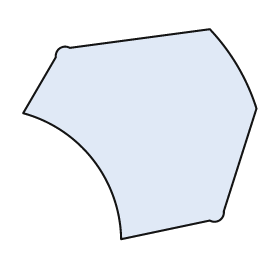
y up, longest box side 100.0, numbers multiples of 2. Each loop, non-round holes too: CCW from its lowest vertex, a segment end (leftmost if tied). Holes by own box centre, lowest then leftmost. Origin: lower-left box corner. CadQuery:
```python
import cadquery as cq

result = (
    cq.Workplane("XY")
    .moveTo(42.0, 0.0)
    .lineTo(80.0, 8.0)
    .threePointArc((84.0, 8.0), (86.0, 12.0))
    .lineTo(100.0, 56.0)
    .threePointArc((92.0, 74.0), (80.0, 90.0))
    .lineTo(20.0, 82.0)
    .threePointArc((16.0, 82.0), (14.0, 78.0))
    .lineTo(0.0, 54.0)
    .threePointArc((30.0, 34.0), (42.0, 0.0))
    .close()
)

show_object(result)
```